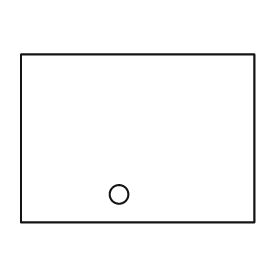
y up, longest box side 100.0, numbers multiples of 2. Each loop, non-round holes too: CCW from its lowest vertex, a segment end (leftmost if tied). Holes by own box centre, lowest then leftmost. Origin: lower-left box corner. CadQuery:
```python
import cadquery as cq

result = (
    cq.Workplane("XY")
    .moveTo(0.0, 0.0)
    .lineTo(100.0, 0.0)
    .lineTo(100.0, 72.0)
    .lineTo(0.0, 72.0)
    .close()
    .moveTo(42.0, 12.0)
    .circle(4.0)
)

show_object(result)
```